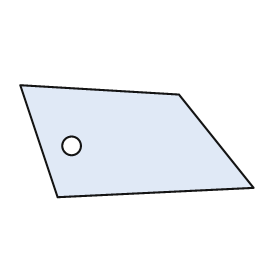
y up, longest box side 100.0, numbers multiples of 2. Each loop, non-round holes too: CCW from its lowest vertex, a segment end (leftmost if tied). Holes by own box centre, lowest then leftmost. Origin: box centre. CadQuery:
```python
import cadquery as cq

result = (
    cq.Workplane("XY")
    .moveTo(-34.0, -24.0)
    .lineTo(50.0, -20.0)
    .lineTo(18.0, 20.0)
    .lineTo(-50.0, 24.0)
    .close()
    .moveTo(-28.0, -2.0)
    .circle(4.0)
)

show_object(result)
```